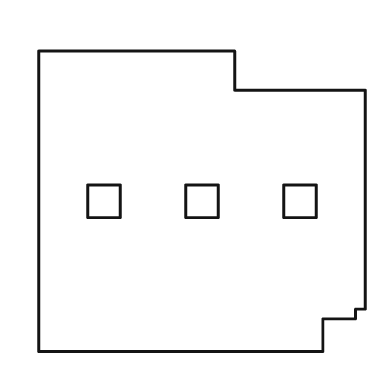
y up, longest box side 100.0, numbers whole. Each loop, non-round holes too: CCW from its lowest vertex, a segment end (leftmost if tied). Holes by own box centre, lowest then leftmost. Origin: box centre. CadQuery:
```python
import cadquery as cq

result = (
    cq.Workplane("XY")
    .moveTo(-50.0, -46.0)
    .lineTo(37.0, -46.0)
    .lineTo(37.0, -36.0)
    .lineTo(47.0, -36.0)
    .lineTo(47.0, -33.0)
    .lineTo(50.0, -33.0)
    .lineTo(50.0, 34.0)
    .lineTo(10.0, 34.0)
    .lineTo(10.0, 46.0)
    .lineTo(-50.0, 46.0)
    .close()
    .moveTo(-35.0, -5.0)
    .lineTo(-25.0, -5.0)
    .lineTo(-25.0, 5.0)
    .lineTo(-35.0, 5.0)
    .close()
    .moveTo(-5.0, -5.0)
    .lineTo(5.0, -5.0)
    .lineTo(5.0, 5.0)
    .lineTo(-5.0, 5.0)
    .close()
    .moveTo(25.0, -5.0)
    .lineTo(35.0, -5.0)
    .lineTo(35.0, 5.0)
    .lineTo(25.0, 5.0)
    .close()
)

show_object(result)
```